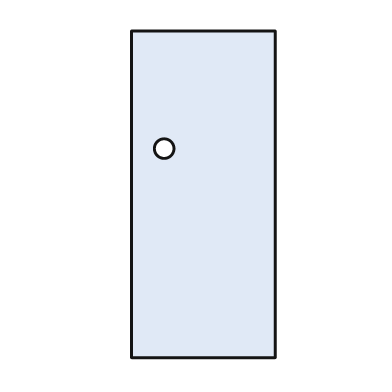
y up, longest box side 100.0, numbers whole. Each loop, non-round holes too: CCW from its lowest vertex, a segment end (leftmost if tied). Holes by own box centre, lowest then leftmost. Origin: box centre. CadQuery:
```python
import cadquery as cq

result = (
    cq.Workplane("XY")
    .moveTo(-22.0, -50.0)
    .lineTo(22.0, -50.0)
    .lineTo(22.0, 50.0)
    .lineTo(-22.0, 50.0)
    .close()
    .moveTo(-12.0, 14.0)
    .circle(3.0)
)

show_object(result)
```